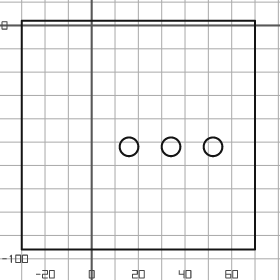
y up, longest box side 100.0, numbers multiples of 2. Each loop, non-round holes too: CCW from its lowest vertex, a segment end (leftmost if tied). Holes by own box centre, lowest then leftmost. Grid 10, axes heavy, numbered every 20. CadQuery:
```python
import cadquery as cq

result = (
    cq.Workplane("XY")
    .moveTo(-30.0, -96.0)
    .lineTo(70.0, -96.0)
    .lineTo(70.0, 2.0)
    .lineTo(-30.0, 2.0)
    .close()
    .moveTo(16.0, -52.0)
    .circle(4.0)
    .moveTo(34.0, -52.0)
    .circle(4.0)
    .moveTo(52.0, -52.0)
    .circle(4.0)
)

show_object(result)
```